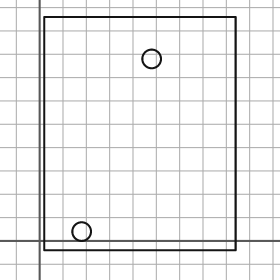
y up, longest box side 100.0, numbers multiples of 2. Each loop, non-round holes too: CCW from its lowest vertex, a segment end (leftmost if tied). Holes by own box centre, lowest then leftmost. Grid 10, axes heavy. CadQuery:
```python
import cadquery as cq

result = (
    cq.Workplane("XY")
    .moveTo(2.0, -4.0)
    .lineTo(84.0, -4.0)
    .lineTo(84.0, 96.0)
    .lineTo(2.0, 96.0)
    .close()
    .moveTo(18.0, 4.0)
    .circle(4.0)
    .moveTo(48.0, 78.0)
    .circle(4.0)
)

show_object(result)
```